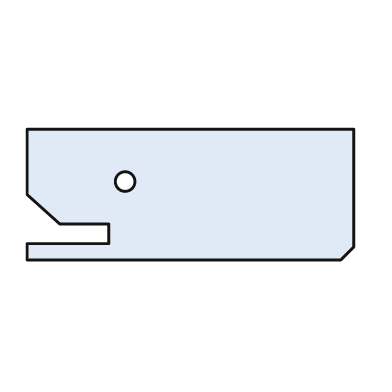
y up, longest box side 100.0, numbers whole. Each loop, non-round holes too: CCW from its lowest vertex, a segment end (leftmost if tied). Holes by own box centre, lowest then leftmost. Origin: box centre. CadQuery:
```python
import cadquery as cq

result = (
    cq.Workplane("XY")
    .moveTo(-50.0, -20.0)
    .lineTo(46.0, -20.0)
    .lineTo(50.0, -16.0)
    .lineTo(50.0, 20.0)
    .lineTo(-50.0, 20.0)
    .lineTo(-50.0, 0.0)
    .lineTo(-40.0, -9.0)
    .lineTo(-25.0, -9.0)
    .lineTo(-25.0, -15.0)
    .lineTo(-50.0, -15.0)
    .close()
    .moveTo(-20.0, 4.0)
    .circle(3.0)
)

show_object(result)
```